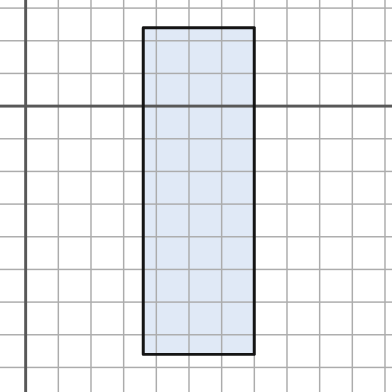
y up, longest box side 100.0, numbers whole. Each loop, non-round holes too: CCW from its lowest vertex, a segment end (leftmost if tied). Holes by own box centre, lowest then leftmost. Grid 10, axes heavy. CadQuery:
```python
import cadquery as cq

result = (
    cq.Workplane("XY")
    .moveTo(36.0, -76.0)
    .lineTo(70.0, -76.0)
    .lineTo(70.0, 24.0)
    .lineTo(36.0, 24.0)
    .close()
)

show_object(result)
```